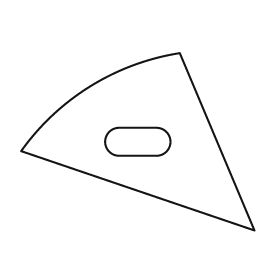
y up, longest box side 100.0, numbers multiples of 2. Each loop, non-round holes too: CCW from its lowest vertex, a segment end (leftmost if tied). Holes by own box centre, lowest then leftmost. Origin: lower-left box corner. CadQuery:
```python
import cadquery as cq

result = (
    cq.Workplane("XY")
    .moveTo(100.0, 0.0)
    .lineTo(68.0, 76.0)
    .threePointArc((30.0, 62.0), (0.0, 34.0))
    .close()
    .moveTo(42.0, 32.0)
    .lineTo(58.0, 32.0)
    .threePointArc((64.0, 38.0), (58.0, 44.0))
    .lineTo(42.0, 44.0)
    .threePointArc((36.0, 38.0), (42.0, 32.0))
    .close()
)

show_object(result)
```